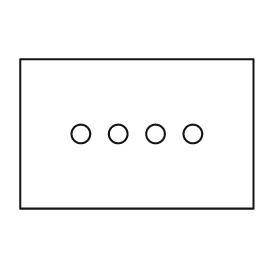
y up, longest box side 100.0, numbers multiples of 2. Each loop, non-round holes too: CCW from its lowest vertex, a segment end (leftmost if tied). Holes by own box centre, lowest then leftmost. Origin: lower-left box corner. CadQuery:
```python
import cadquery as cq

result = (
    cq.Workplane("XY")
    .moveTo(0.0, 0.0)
    .lineTo(100.0, 0.0)
    .lineTo(100.0, 64.0)
    .lineTo(0.0, 64.0)
    .close()
    .moveTo(26.0, 32.0)
    .circle(4.0)
    .moveTo(42.0, 32.0)
    .circle(4.0)
    .moveTo(58.0, 32.0)
    .circle(4.0)
    .moveTo(74.0, 32.0)
    .circle(4.0)
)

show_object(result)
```